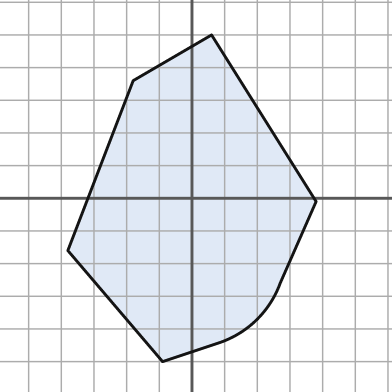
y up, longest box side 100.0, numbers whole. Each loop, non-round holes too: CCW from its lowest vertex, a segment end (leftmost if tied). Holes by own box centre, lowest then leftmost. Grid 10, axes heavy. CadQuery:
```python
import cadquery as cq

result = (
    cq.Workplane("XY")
    .moveTo(-9.0, -50.0)
    .lineTo(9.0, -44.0)
    .threePointArc((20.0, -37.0), (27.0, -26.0))
    .lineTo(38.0, -1.0)
    .lineTo(6.0, 50.0)
    .lineTo(-18.0, 36.0)
    .lineTo(-38.0, -16.0)
    .close()
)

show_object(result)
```